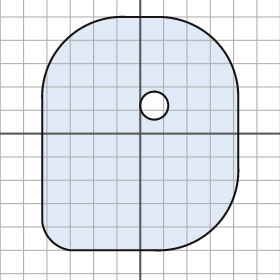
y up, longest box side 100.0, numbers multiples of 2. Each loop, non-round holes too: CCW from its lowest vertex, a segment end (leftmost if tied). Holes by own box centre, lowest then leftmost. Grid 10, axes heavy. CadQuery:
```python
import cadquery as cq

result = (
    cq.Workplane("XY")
    .moveTo(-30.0, -50.0)
    .lineTo(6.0, -50.0)
    .threePointArc((32.0, -40.0), (42.0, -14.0))
    .lineTo(42.0, 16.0)
    .threePointArc((32.0, 40.0), (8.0, 50.0))
    .lineTo(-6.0, 50.0)
    .threePointArc((-32.0, 40.0), (-42.0, 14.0))
    .lineTo(-42.0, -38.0)
    .threePointArc((-38.0, -46.0), (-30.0, -50.0))
    .close()
    .moveTo(6.0, 12.0)
    .circle(6.0)
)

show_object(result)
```